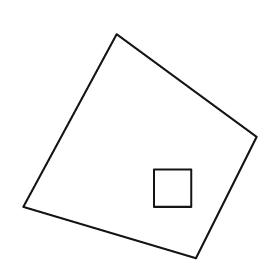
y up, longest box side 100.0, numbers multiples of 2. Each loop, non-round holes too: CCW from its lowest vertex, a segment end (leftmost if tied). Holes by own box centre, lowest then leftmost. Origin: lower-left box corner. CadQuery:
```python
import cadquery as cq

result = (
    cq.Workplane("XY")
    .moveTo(74.0, 0.0)
    .lineTo(100.0, 52.0)
    .lineTo(40.0, 96.0)
    .lineTo(0.0, 22.0)
    .close()
    .moveTo(56.0, 22.0)
    .lineTo(72.0, 22.0)
    .lineTo(72.0, 38.0)
    .lineTo(56.0, 38.0)
    .close()
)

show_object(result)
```